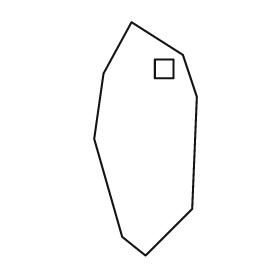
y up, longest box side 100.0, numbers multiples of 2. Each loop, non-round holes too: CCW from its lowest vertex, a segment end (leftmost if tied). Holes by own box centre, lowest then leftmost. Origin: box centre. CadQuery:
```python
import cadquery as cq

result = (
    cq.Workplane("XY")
    .moveTo(0.0, -50.0)
    .lineTo(20.0, -30.0)
    .lineTo(22.0, 18.0)
    .lineTo(16.0, 36.0)
    .lineTo(-6.0, 50.0)
    .lineTo(-18.0, 28.0)
    .lineTo(-22.0, 0.0)
    .lineTo(-10.0, -42.0)
    .close()
    .moveTo(4.0, 26.0)
    .lineTo(12.0, 26.0)
    .lineTo(12.0, 34.0)
    .lineTo(4.0, 34.0)
    .close()
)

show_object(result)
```